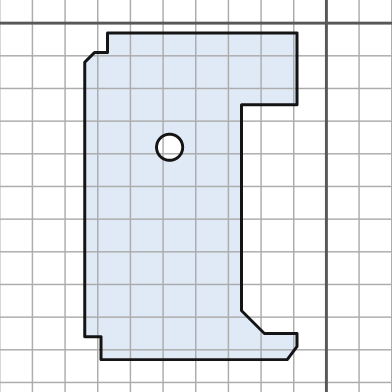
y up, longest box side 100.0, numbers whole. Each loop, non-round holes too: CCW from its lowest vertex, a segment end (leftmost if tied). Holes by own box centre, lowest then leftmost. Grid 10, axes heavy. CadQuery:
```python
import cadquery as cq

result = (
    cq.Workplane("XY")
    .moveTo(-69.0, -103.0)
    .lineTo(-12.0, -103.0)
    .lineTo(-9.0, -99.0)
    .lineTo(-9.0, -95.0)
    .lineTo(-19.0, -95.0)
    .lineTo(-26.0, -88.0)
    .lineTo(-26.0, -25.0)
    .lineTo(-9.0, -25.0)
    .lineTo(-9.0, -3.0)
    .lineTo(-67.0, -3.0)
    .lineTo(-67.0, -9.0)
    .lineTo(-71.0, -9.0)
    .lineTo(-74.0, -12.0)
    .lineTo(-74.0, -96.0)
    .lineTo(-69.0, -96.0)
    .close()
    .moveTo(-48.0, -38.0)
    .circle(4.0)
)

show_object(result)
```